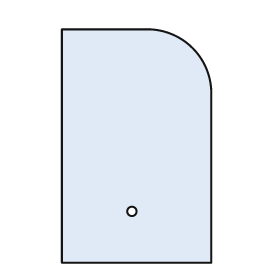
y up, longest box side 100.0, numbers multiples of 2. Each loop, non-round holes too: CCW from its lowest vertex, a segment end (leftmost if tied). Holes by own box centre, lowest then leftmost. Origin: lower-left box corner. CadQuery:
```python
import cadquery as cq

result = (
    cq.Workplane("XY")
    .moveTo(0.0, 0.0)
    .lineTo(64.0, 0.0)
    .lineTo(64.0, 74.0)
    .threePointArc((56.0, 92.0), (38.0, 100.0))
    .lineTo(0.0, 100.0)
    .close()
    .moveTo(30.0, 22.0)
    .circle(2.0)
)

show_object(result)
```